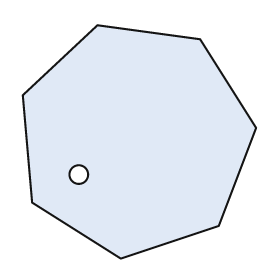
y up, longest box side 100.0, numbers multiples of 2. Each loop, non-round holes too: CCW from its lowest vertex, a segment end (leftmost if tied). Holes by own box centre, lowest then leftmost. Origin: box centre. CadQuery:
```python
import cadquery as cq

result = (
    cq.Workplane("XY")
    .moveTo(-8.0, -50.0)
    .lineTo(34.0, -36.0)
    .lineTo(50.0, 6.0)
    .lineTo(26.0, 44.0)
    .lineTo(-18.0, 50.0)
    .lineTo(-50.0, 20.0)
    .lineTo(-46.0, -26.0)
    .close()
    .moveTo(-26.0, -14.0)
    .circle(4.0)
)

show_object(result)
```